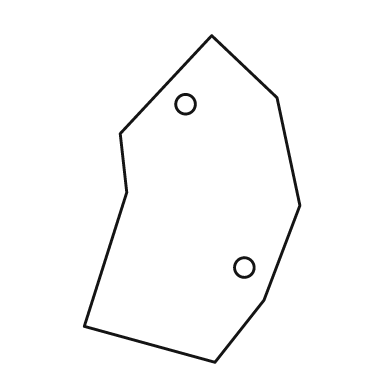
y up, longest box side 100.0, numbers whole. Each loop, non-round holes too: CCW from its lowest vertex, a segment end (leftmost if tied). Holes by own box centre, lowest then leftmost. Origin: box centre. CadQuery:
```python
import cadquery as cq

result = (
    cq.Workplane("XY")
    .moveTo(7.0, -50.0)
    .lineTo(22.0, -31.0)
    .lineTo(33.0, -2.0)
    .lineTo(26.0, 31.0)
    .lineTo(6.0, 50.0)
    .lineTo(-22.0, 20.0)
    .lineTo(-20.0, 2.0)
    .lineTo(-33.0, -39.0)
    .close()
    .moveTo(16.0, -21.0)
    .circle(3.0)
    .moveTo(-2.0, 29.0)
    .circle(3.0)
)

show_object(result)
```